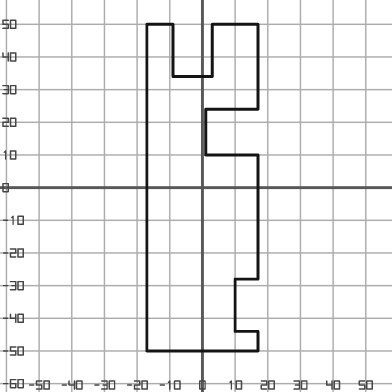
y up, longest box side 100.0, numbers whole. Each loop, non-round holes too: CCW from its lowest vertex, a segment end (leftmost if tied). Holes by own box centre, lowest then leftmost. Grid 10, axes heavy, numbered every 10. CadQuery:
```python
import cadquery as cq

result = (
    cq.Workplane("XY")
    .moveTo(-17.0, -50.0)
    .lineTo(17.0, -50.0)
    .lineTo(17.0, -44.0)
    .lineTo(10.0, -44.0)
    .lineTo(10.0, -28.0)
    .lineTo(17.0, -28.0)
    .lineTo(17.0, 10.0)
    .lineTo(1.0, 10.0)
    .lineTo(1.0, 24.0)
    .lineTo(17.0, 24.0)
    .lineTo(17.0, 50.0)
    .lineTo(3.0, 50.0)
    .lineTo(3.0, 34.0)
    .lineTo(-9.0, 34.0)
    .lineTo(-9.0, 50.0)
    .lineTo(-17.0, 50.0)
    .close()
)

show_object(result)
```